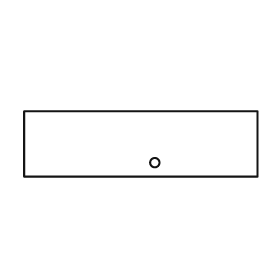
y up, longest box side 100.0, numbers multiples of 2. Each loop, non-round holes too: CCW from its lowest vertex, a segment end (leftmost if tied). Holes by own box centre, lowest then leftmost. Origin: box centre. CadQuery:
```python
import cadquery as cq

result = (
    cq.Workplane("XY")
    .moveTo(-50.0, -14.0)
    .lineTo(50.0, -14.0)
    .lineTo(50.0, 14.0)
    .lineTo(-50.0, 14.0)
    .close()
    .moveTo(6.0, -8.0)
    .circle(2.0)
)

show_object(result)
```